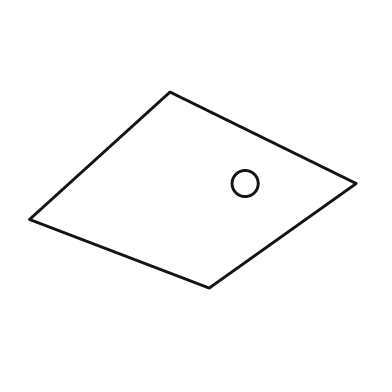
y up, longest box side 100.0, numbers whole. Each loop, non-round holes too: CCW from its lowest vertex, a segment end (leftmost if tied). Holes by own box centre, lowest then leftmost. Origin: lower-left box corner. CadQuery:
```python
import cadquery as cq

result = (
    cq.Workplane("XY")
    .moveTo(55.0, 0.0)
    .lineTo(100.0, 32.0)
    .lineTo(43.0, 60.0)
    .lineTo(0.0, 21.0)
    .close()
    .moveTo(66.0, 32.0)
    .circle(4.0)
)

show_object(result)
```